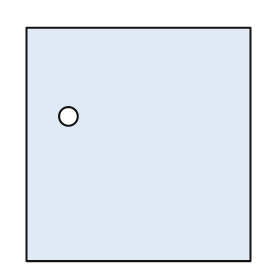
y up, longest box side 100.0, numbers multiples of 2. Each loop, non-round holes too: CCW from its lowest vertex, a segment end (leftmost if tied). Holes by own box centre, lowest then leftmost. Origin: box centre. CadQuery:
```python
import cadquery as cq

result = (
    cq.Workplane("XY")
    .moveTo(-48.0, -50.0)
    .lineTo(48.0, -50.0)
    .lineTo(48.0, 50.0)
    .lineTo(-48.0, 50.0)
    .close()
    .moveTo(-30.0, 12.0)
    .circle(4.0)
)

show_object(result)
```